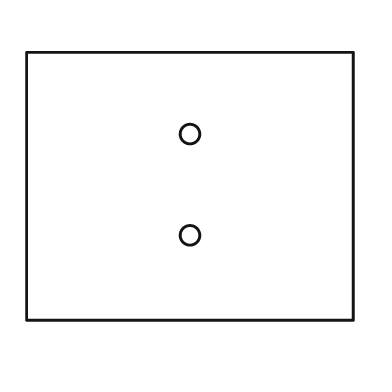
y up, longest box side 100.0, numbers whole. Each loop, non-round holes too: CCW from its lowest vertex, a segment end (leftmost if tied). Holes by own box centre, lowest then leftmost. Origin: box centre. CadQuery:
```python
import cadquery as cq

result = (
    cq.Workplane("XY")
    .moveTo(-50.0, -41.0)
    .lineTo(50.0, -41.0)
    .lineTo(50.0, 41.0)
    .lineTo(-50.0, 41.0)
    .close()
    .moveTo(0.0, -15.0)
    .circle(3.0)
    .moveTo(0.0, 16.0)
    .circle(3.0)
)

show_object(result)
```